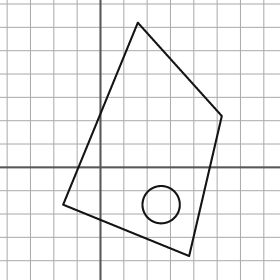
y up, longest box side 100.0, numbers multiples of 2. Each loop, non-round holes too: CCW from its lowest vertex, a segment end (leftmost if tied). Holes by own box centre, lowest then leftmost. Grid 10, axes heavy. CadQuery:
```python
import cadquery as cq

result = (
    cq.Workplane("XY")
    .moveTo(38.0, -38.0)
    .lineTo(52.0, 22.0)
    .lineTo(16.0, 62.0)
    .lineTo(-16.0, -16.0)
    .close()
    .moveTo(26.0, -16.0)
    .circle(8.0)
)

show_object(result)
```